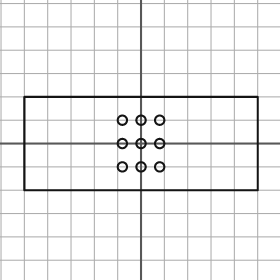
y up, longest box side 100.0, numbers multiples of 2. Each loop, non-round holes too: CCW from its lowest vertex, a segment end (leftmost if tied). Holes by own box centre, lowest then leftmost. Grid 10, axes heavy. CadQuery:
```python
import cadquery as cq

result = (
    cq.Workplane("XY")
    .moveTo(-50.0, -20.0)
    .lineTo(50.0, -20.0)
    .lineTo(50.0, 20.0)
    .lineTo(-50.0, 20.0)
    .close()
    .moveTo(-8.0, -10.0)
    .circle(2.0)
    .moveTo(0.0, -10.0)
    .circle(2.0)
    .moveTo(8.0, -10.0)
    .circle(2.0)
    .moveTo(-8.0, 0.0)
    .circle(2.0)
    .moveTo(0.0, 0.0)
    .circle(2.0)
    .moveTo(8.0, 0.0)
    .circle(2.0)
    .moveTo(-8.0, 10.0)
    .circle(2.0)
    .moveTo(0.0, 10.0)
    .circle(2.0)
    .moveTo(8.0, 10.0)
    .circle(2.0)
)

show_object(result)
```